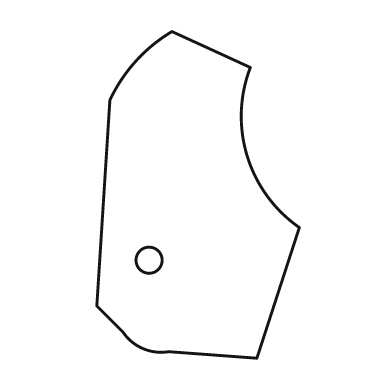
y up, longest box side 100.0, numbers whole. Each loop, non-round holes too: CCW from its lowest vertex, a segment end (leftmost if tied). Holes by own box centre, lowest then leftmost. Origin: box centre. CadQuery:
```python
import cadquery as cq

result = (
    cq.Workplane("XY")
    .moveTo(18.0, -50.0)
    .lineTo(31.0, -10.0)
    .threePointArc((15.0, 12.0), (16.0, 39.0))
    .lineTo(-8.0, 50.0)
    .threePointArc((-19.0, 41.0), (-27.0, 29.0))
    .lineTo(-31.0, -34.0)
    .lineTo(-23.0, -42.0)
    .threePointArc((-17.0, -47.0), (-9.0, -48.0))
    .close()
    .moveTo(-15.0, -20.0)
    .circle(4.0)
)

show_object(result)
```